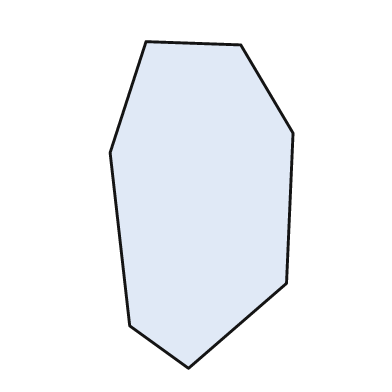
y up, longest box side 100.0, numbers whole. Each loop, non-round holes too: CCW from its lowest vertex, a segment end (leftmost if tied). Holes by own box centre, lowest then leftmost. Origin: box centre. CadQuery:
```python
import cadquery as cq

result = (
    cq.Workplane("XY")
    .moveTo(-4.0, -50.0)
    .lineTo(26.0, -24.0)
    .lineTo(28.0, 22.0)
    .lineTo(12.0, 49.0)
    .lineTo(-17.0, 50.0)
    .lineTo(-28.0, 16.0)
    .lineTo(-22.0, -37.0)
    .close()
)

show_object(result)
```